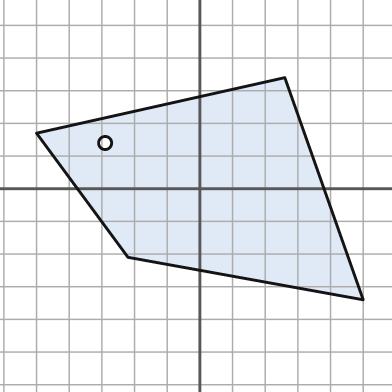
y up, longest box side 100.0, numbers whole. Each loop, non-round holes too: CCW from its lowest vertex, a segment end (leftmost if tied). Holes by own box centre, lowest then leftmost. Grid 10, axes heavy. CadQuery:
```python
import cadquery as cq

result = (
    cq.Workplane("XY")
    .moveTo(50.0, -34.0)
    .lineTo(26.0, 34.0)
    .lineTo(-50.0, 17.0)
    .lineTo(-22.0, -21.0)
    .close()
    .moveTo(-29.0, 14.0)
    .circle(2.0)
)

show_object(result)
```